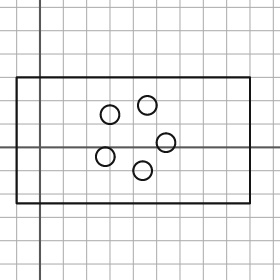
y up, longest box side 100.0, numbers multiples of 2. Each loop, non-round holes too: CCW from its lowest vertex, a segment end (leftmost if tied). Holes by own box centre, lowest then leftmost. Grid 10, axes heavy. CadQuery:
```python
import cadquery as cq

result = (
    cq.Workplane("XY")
    .moveTo(-10.0, -24.0)
    .lineTo(90.0, -24.0)
    .lineTo(90.0, 30.0)
    .lineTo(-10.0, 30.0)
    .close()
    .moveTo(44.0, -10.0)
    .circle(4.0)
    .moveTo(28.0, -4.0)
    .circle(4.0)
    .moveTo(54.0, 2.0)
    .circle(4.0)
    .moveTo(30.0, 14.0)
    .circle(4.0)
    .moveTo(46.0, 18.0)
    .circle(4.0)
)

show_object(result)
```